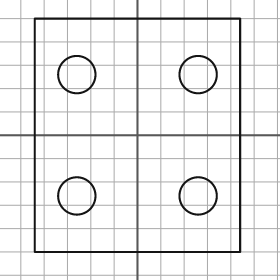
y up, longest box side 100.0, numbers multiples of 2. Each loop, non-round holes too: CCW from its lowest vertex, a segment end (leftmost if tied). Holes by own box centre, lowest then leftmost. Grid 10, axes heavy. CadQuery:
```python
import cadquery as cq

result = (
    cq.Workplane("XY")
    .moveTo(-44.0, -50.0)
    .lineTo(44.0, -50.0)
    .lineTo(44.0, 50.0)
    .lineTo(-44.0, 50.0)
    .close()
    .moveTo(-26.0, -26.0)
    .circle(8.0)
    .moveTo(26.0, -26.0)
    .circle(8.0)
    .moveTo(-26.0, 26.0)
    .circle(8.0)
    .moveTo(26.0, 26.0)
    .circle(8.0)
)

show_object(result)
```